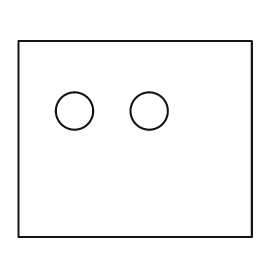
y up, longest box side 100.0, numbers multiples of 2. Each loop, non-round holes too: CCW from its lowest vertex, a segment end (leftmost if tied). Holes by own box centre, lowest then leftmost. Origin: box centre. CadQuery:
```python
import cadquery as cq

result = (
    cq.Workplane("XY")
    .moveTo(-50.0, -42.0)
    .lineTo(50.0, -42.0)
    .lineTo(50.0, 42.0)
    .lineTo(-50.0, 42.0)
    .close()
    .moveTo(-26.0, 12.0)
    .circle(8.0)
    .moveTo(6.0, 12.0)
    .circle(8.0)
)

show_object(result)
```